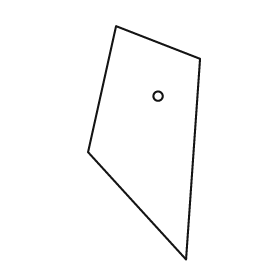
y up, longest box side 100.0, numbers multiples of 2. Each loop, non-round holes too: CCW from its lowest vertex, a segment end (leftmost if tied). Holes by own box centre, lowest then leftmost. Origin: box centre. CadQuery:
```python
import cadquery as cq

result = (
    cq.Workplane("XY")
    .moveTo(18.0, -50.0)
    .lineTo(24.0, 36.0)
    .lineTo(-12.0, 50.0)
    .lineTo(-24.0, -4.0)
    .close()
    .moveTo(6.0, 20.0)
    .circle(2.0)
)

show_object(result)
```